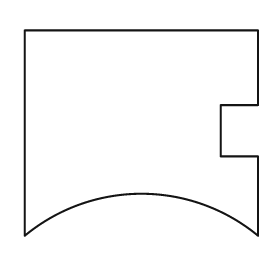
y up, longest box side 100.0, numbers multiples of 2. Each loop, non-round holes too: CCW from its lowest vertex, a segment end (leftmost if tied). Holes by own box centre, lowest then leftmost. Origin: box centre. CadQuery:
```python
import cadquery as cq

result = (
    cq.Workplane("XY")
    .moveTo(-50.0, -44.0)
    .threePointArc((0.0, -26.0), (50.0, -44.0))
    .lineTo(50.0, -10.0)
    .lineTo(34.0, -10.0)
    .lineTo(34.0, 12.0)
    .lineTo(50.0, 12.0)
    .lineTo(50.0, 44.0)
    .lineTo(-50.0, 44.0)
    .close()
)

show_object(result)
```